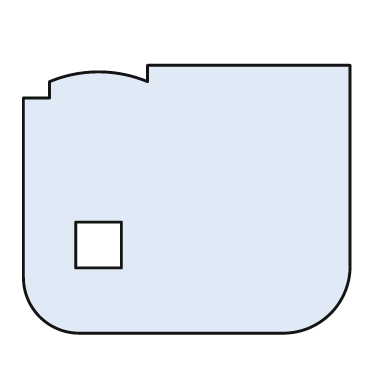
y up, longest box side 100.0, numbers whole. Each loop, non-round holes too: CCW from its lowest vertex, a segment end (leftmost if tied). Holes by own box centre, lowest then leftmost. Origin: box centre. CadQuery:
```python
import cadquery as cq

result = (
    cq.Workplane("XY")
    .moveTo(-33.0, -41.0)
    .lineTo(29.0, -41.0)
    .threePointArc((44.0, -35.0), (50.0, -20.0))
    .lineTo(50.0, 41.0)
    .lineTo(-12.0, 41.0)
    .lineTo(-12.0, 36.0)
    .threePointArc((-27.0, 39.0), (-42.0, 36.0))
    .lineTo(-42.0, 31.0)
    .lineTo(-50.0, 31.0)
    .lineTo(-50.0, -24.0)
    .threePointArc((-45.0, -36.0), (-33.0, -41.0))
    .close()
    .moveTo(-34.0, -21.0)
    .lineTo(-20.0, -21.0)
    .lineTo(-20.0, -7.0)
    .lineTo(-34.0, -7.0)
    .close()
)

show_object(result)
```